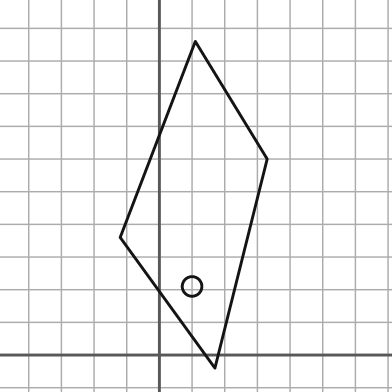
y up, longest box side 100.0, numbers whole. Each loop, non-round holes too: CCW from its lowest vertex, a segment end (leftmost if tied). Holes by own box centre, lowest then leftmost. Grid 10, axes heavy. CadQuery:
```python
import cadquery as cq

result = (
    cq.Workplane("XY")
    .moveTo(17.0, -4.0)
    .lineTo(33.0, 60.0)
    .lineTo(11.0, 96.0)
    .lineTo(-12.0, 36.0)
    .close()
    .moveTo(10.0, 21.0)
    .circle(3.0)
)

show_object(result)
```